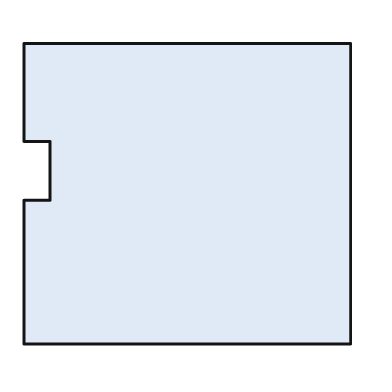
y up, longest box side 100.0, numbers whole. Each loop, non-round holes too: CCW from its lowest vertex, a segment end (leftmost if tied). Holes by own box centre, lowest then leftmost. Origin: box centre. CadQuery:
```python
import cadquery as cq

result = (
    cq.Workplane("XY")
    .moveTo(-50.0, -46.0)
    .lineTo(50.0, -46.0)
    .lineTo(50.0, 46.0)
    .lineTo(-50.0, 46.0)
    .lineTo(-50.0, 16.0)
    .lineTo(-42.0, 16.0)
    .lineTo(-42.0, -2.0)
    .lineTo(-50.0, -2.0)
    .close()
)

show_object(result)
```